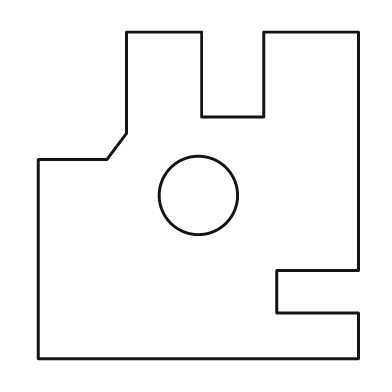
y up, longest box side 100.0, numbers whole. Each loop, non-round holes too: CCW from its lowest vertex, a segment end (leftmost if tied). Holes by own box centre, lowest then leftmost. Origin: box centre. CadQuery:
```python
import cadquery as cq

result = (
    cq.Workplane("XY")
    .moveTo(-49.0, -50.0)
    .lineTo(49.0, -50.0)
    .lineTo(49.0, -36.0)
    .lineTo(24.0, -36.0)
    .lineTo(24.0, -23.0)
    .lineTo(49.0, -23.0)
    .lineTo(49.0, 50.0)
    .lineTo(20.0, 50.0)
    .lineTo(20.0, 24.0)
    .lineTo(1.0, 24.0)
    .lineTo(1.0, 50.0)
    .lineTo(-22.0, 50.0)
    .lineTo(-22.0, 19.0)
    .lineTo(-28.0, 11.0)
    .lineTo(-49.0, 11.0)
    .close()
    .moveTo(0.0, 0.0)
    .circle(12.0)
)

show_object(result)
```